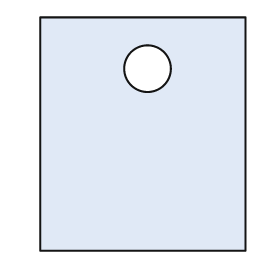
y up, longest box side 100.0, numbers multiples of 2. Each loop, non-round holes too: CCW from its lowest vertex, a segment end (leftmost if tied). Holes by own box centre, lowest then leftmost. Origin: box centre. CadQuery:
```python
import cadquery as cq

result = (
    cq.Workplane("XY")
    .moveTo(-44.0, -50.0)
    .lineTo(44.0, -50.0)
    .lineTo(44.0, 50.0)
    .lineTo(-44.0, 50.0)
    .close()
    .moveTo(2.0, 28.0)
    .circle(10.0)
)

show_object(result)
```